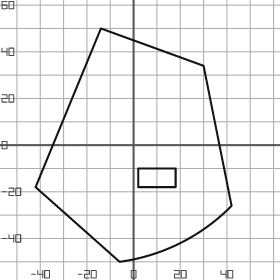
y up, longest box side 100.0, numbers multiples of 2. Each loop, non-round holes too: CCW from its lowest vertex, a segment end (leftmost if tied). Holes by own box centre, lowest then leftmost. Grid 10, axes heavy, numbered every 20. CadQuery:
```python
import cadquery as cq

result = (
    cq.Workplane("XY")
    .moveTo(-6.0, -50.0)
    .threePointArc((20.0, -42.0), (42.0, -26.0))
    .lineTo(30.0, 34.0)
    .lineTo(-14.0, 50.0)
    .lineTo(-42.0, -18.0)
    .close()
    .moveTo(2.0, -18.0)
    .lineTo(18.0, -18.0)
    .lineTo(18.0, -10.0)
    .lineTo(2.0, -10.0)
    .close()
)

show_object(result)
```